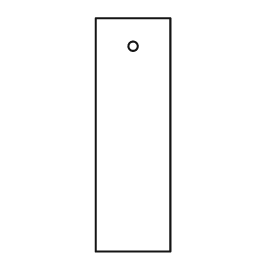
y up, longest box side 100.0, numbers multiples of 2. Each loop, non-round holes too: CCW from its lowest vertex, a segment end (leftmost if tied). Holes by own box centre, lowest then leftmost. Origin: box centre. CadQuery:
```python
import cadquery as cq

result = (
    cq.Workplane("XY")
    .moveTo(-16.0, -50.0)
    .lineTo(16.0, -50.0)
    .lineTo(16.0, 50.0)
    .lineTo(-16.0, 50.0)
    .close()
    .moveTo(0.0, 38.0)
    .circle(2.0)
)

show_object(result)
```